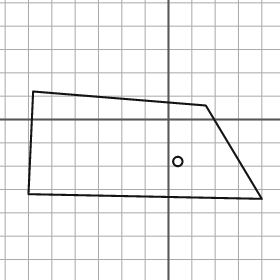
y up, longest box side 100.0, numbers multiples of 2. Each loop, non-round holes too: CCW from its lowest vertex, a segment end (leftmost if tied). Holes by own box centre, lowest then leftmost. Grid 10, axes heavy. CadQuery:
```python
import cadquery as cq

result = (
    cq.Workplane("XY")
    .moveTo(40.0, -34.0)
    .lineTo(16.0, 6.0)
    .lineTo(-58.0, 12.0)
    .lineTo(-60.0, -32.0)
    .close()
    .moveTo(4.0, -18.0)
    .circle(2.0)
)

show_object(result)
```